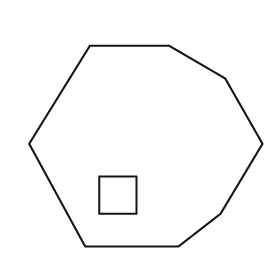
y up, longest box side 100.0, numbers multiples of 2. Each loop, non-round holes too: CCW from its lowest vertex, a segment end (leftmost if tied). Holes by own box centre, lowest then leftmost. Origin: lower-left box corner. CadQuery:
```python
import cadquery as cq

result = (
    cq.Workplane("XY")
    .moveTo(24.0, 0.0)
    .lineTo(64.0, 0.0)
    .lineTo(82.0, 14.0)
    .lineTo(100.0, 44.0)
    .lineTo(84.0, 72.0)
    .lineTo(60.0, 86.0)
    .lineTo(26.0, 86.0)
    .lineTo(0.0, 44.0)
    .close()
    .moveTo(30.0, 14.0)
    .lineTo(46.0, 14.0)
    .lineTo(46.0, 30.0)
    .lineTo(30.0, 30.0)
    .close()
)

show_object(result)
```